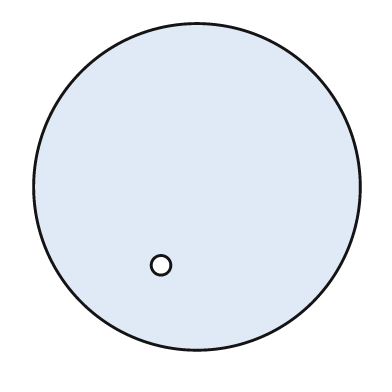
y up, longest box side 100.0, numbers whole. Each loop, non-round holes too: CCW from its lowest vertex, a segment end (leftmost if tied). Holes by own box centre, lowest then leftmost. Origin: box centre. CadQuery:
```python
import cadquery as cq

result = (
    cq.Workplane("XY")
    .moveTo(0.0, 0.0)
    .circle(50.0)
    .moveTo(-11.0, -24.0)
    .circle(3.0)
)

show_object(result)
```